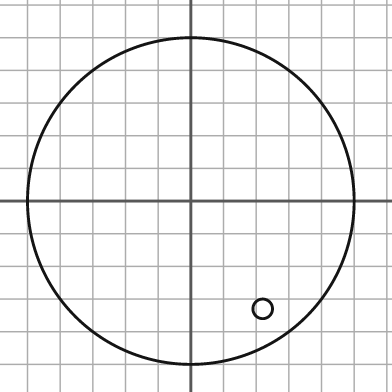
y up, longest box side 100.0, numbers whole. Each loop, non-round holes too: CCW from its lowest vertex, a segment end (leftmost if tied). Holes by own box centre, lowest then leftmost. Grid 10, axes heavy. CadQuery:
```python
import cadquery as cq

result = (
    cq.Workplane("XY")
    .moveTo(0.0, 0.0)
    .circle(50.0)
    .moveTo(22.0, -33.0)
    .circle(3.0)
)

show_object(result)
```